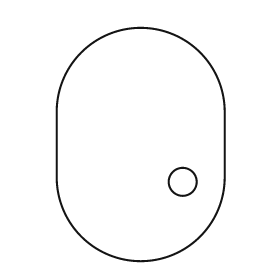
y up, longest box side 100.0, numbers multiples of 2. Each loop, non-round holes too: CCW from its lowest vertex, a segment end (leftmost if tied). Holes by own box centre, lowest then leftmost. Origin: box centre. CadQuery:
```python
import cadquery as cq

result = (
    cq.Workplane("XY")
    .moveTo(-36.0, -14.0)
    .threePointArc((0.0, -50.0), (36.0, -14.0))
    .lineTo(36.0, 14.0)
    .threePointArc((0.0, 50.0), (-36.0, 14.0))
    .close()
    .moveTo(18.0, -16.0)
    .circle(6.0)
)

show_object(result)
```